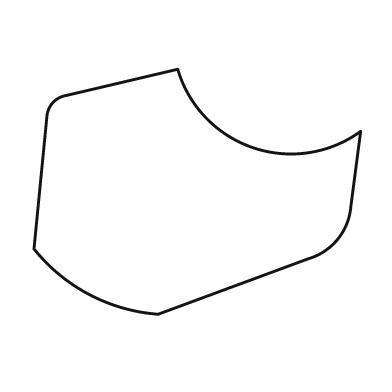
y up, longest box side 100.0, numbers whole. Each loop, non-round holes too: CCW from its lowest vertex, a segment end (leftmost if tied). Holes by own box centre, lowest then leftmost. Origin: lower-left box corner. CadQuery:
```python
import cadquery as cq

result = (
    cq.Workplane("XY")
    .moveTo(38.0, 0.0)
    .lineTo(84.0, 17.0)
    .threePointArc((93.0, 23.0), (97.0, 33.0))
    .lineTo(100.0, 56.0)
    .threePointArc((67.0, 51.0), (44.0, 75.0))
    .lineTo(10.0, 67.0)
    .threePointArc((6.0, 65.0), (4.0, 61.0))
    .lineTo(0.0, 20.0)
    .threePointArc((17.0, 6.0), (38.0, 0.0))
    .close()
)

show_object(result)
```